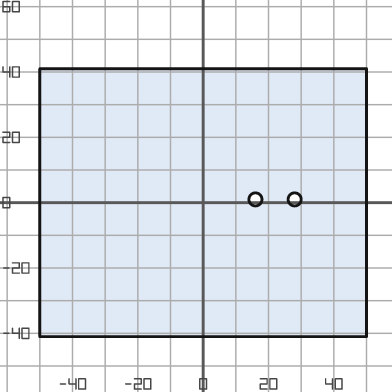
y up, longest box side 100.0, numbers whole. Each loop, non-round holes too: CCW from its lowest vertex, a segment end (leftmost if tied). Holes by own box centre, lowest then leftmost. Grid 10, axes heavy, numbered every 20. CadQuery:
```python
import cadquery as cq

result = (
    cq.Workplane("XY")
    .moveTo(-50.0, -41.0)
    .lineTo(50.0, -41.0)
    .lineTo(50.0, 41.0)
    .lineTo(-50.0, 41.0)
    .close()
    .moveTo(16.0, 1.0)
    .circle(2.0)
    .moveTo(28.0, 1.0)
    .circle(2.0)
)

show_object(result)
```